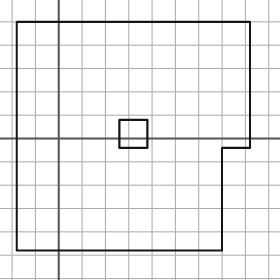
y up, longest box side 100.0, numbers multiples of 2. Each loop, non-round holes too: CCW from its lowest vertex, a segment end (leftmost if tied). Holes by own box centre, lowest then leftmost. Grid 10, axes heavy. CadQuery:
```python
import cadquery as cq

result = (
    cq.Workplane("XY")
    .moveTo(-18.0, -48.0)
    .lineTo(70.0, -48.0)
    .lineTo(70.0, -4.0)
    .lineTo(82.0, -4.0)
    .lineTo(82.0, 50.0)
    .lineTo(-18.0, 50.0)
    .close()
    .moveTo(26.0, -4.0)
    .lineTo(38.0, -4.0)
    .lineTo(38.0, 8.0)
    .lineTo(26.0, 8.0)
    .close()
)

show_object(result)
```